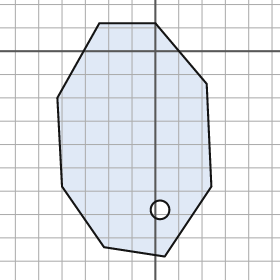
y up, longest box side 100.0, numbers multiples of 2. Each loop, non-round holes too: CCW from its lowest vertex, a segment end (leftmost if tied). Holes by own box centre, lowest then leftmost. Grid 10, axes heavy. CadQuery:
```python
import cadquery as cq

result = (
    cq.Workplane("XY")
    .moveTo(4.0, -88.0)
    .lineTo(24.0, -58.0)
    .lineTo(22.0, -14.0)
    .lineTo(0.0, 12.0)
    .lineTo(-24.0, 12.0)
    .lineTo(-42.0, -20.0)
    .lineTo(-40.0, -58.0)
    .lineTo(-22.0, -84.0)
    .close()
    .moveTo(2.0, -68.0)
    .circle(4.0)
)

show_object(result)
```